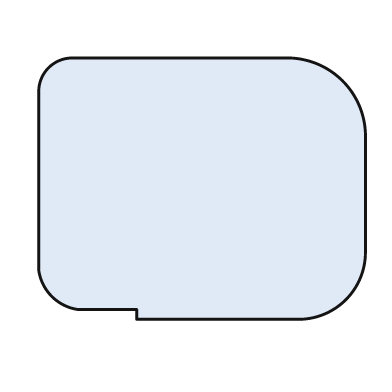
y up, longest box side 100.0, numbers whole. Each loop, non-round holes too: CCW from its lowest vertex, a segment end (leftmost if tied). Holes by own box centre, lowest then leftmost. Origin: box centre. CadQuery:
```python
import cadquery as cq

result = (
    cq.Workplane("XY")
    .moveTo(-20.0, -40.0)
    .lineTo(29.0, -40.0)
    .threePointArc((44.0, -34.0), (50.0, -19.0))
    .lineTo(50.0, 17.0)
    .threePointArc((43.0, 33.0), (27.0, 40.0))
    .lineTo(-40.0, 40.0)
    .threePointArc((-47.0, 37.0), (-50.0, 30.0))
    .lineTo(-50.0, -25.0)
    .threePointArc((-46.0, -33.0), (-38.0, -37.0))
    .lineTo(-20.0, -37.0)
    .close()
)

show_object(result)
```